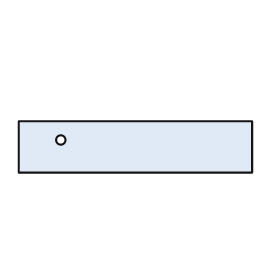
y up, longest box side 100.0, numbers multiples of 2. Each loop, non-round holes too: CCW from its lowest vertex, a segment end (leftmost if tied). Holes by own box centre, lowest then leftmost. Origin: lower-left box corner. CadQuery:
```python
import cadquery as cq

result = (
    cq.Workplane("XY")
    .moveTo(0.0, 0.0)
    .lineTo(100.0, 0.0)
    .lineTo(100.0, 22.0)
    .lineTo(0.0, 22.0)
    .close()
    .moveTo(18.0, 14.0)
    .circle(2.0)
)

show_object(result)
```